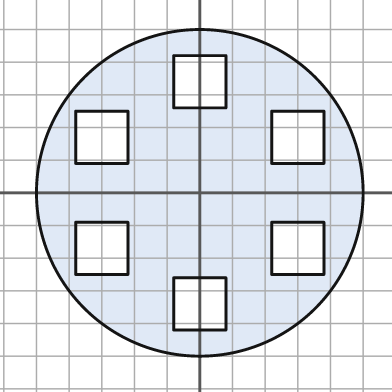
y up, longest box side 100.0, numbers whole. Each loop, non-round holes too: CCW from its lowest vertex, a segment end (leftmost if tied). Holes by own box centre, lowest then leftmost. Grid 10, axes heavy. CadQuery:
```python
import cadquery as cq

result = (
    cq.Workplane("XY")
    .moveTo(0.0, 0.0)
    .circle(50.0)
    .moveTo(-8.0, -42.0)
    .lineTo(8.0, -42.0)
    .lineTo(8.0, -26.0)
    .lineTo(-8.0, -26.0)
    .close()
    .moveTo(-38.0, -25.0)
    .lineTo(-22.0, -25.0)
    .lineTo(-22.0, -9.0)
    .lineTo(-38.0, -9.0)
    .close()
    .moveTo(22.0, -25.0)
    .lineTo(38.0, -25.0)
    .lineTo(38.0, -9.0)
    .lineTo(22.0, -9.0)
    .close()
    .moveTo(-38.0, 9.0)
    .lineTo(-22.0, 9.0)
    .lineTo(-22.0, 25.0)
    .lineTo(-38.0, 25.0)
    .close()
    .moveTo(22.0, 9.0)
    .lineTo(38.0, 9.0)
    .lineTo(38.0, 25.0)
    .lineTo(22.0, 25.0)
    .close()
    .moveTo(-8.0, 26.0)
    .lineTo(8.0, 26.0)
    .lineTo(8.0, 42.0)
    .lineTo(-8.0, 42.0)
    .close()
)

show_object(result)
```